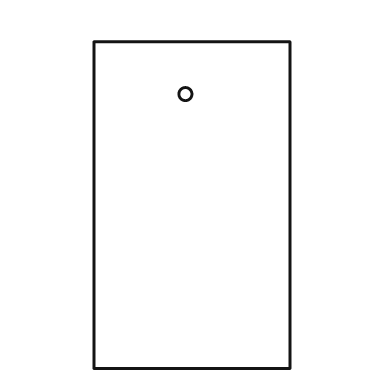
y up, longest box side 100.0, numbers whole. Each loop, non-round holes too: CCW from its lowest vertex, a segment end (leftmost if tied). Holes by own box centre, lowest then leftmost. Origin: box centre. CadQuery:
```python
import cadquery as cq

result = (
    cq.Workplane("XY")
    .moveTo(-30.0, -50.0)
    .lineTo(30.0, -50.0)
    .lineTo(30.0, 50.0)
    .lineTo(-30.0, 50.0)
    .close()
    .moveTo(-2.0, 34.0)
    .circle(2.0)
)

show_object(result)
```